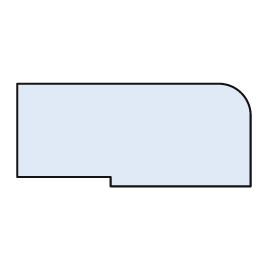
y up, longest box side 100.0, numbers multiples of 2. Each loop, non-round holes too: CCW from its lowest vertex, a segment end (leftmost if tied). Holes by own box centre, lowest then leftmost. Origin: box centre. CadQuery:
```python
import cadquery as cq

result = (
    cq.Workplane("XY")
    .moveTo(-10.0, -22.0)
    .lineTo(50.0, -22.0)
    .lineTo(50.0, 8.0)
    .threePointArc((46.0, 18.0), (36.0, 22.0))
    .lineTo(-50.0, 22.0)
    .lineTo(-50.0, -18.0)
    .lineTo(-10.0, -18.0)
    .close()
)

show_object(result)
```